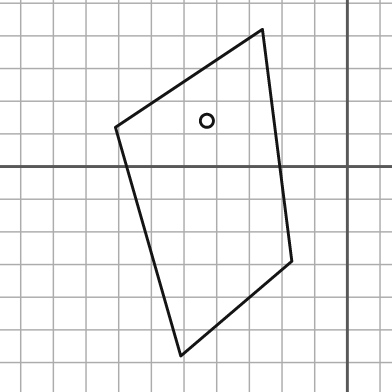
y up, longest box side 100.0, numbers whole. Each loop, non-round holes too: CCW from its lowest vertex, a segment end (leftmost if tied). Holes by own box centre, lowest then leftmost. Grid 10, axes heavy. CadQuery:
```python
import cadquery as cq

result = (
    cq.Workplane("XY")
    .moveTo(-51.0, -58.0)
    .lineTo(-17.0, -29.0)
    .lineTo(-26.0, 42.0)
    .lineTo(-71.0, 12.0)
    .close()
    .moveTo(-43.0, 14.0)
    .circle(2.0)
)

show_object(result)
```